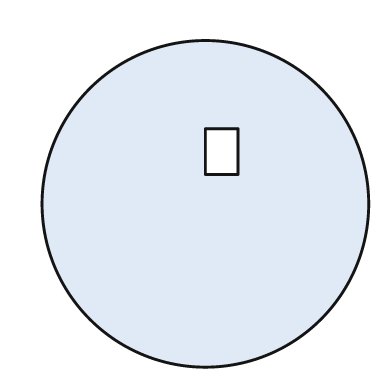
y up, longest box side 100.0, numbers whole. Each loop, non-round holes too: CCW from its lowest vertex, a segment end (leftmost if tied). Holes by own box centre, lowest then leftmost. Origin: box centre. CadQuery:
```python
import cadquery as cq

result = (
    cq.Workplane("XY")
    .moveTo(0.0, 0.0)
    .circle(50.0)
    .moveTo(0.0, 9.0)
    .lineTo(10.0, 9.0)
    .lineTo(10.0, 23.0)
    .lineTo(0.0, 23.0)
    .close()
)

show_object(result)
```